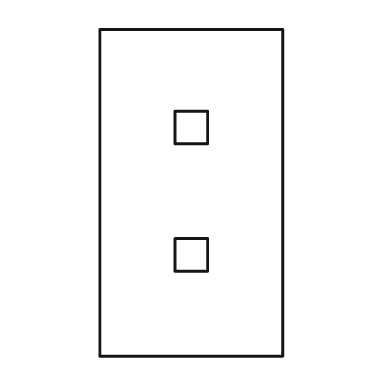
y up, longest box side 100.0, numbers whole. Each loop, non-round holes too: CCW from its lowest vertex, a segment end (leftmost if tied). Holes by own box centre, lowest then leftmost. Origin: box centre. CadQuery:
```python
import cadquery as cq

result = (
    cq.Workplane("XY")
    .moveTo(-28.0, -50.0)
    .lineTo(28.0, -50.0)
    .lineTo(28.0, 50.0)
    .lineTo(-28.0, 50.0)
    .close()
    .moveTo(-5.0, -24.0)
    .lineTo(5.0, -24.0)
    .lineTo(5.0, -14.0)
    .lineTo(-5.0, -14.0)
    .close()
    .moveTo(-5.0, 15.0)
    .lineTo(5.0, 15.0)
    .lineTo(5.0, 25.0)
    .lineTo(-5.0, 25.0)
    .close()
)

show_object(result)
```